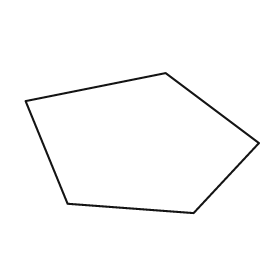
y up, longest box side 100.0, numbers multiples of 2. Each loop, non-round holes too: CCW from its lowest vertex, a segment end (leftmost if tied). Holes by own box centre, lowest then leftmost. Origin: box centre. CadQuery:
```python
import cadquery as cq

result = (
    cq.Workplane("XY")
    .moveTo(22.0, -30.0)
    .lineTo(50.0, 0.0)
    .lineTo(10.0, 30.0)
    .lineTo(-50.0, 18.0)
    .lineTo(-32.0, -26.0)
    .close()
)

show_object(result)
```